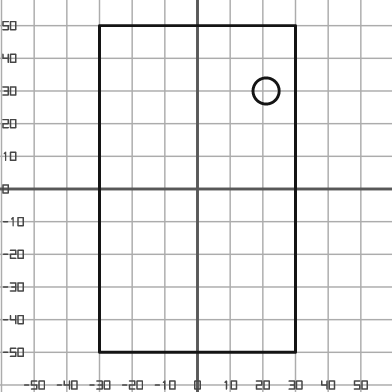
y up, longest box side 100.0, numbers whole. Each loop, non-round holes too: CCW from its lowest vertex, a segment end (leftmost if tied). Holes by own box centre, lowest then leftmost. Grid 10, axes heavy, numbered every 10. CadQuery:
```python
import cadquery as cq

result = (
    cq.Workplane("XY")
    .moveTo(-30.0, -50.0)
    .lineTo(30.0, -50.0)
    .lineTo(30.0, 50.0)
    .lineTo(-30.0, 50.0)
    .close()
    .moveTo(21.0, 30.0)
    .circle(4.0)
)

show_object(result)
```